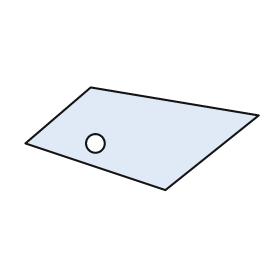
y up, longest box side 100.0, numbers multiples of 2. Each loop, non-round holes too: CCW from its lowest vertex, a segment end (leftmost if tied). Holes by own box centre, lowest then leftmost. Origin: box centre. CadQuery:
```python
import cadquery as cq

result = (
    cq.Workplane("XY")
    .moveTo(10.0, -22.0)
    .lineTo(50.0, 10.0)
    .lineTo(-22.0, 22.0)
    .lineTo(-50.0, -2.0)
    .close()
    .moveTo(-20.0, -2.0)
    .circle(4.0)
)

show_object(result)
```